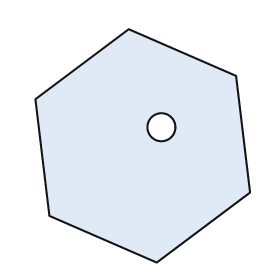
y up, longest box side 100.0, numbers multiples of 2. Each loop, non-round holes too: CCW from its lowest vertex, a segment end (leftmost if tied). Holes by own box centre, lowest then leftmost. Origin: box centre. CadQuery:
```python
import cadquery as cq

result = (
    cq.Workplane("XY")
    .moveTo(6.0, -50.0)
    .lineTo(46.0, -20.0)
    .lineTo(40.0, 30.0)
    .lineTo(-6.0, 50.0)
    .lineTo(-46.0, 20.0)
    .lineTo(-40.0, -30.0)
    .close()
    .moveTo(8.0, 8.0)
    .circle(6.0)
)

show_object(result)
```